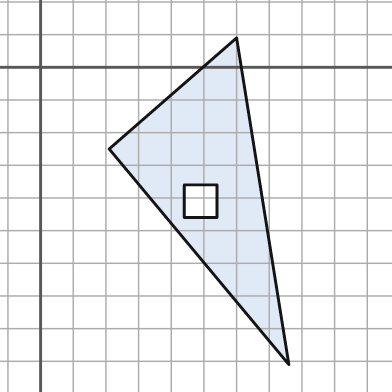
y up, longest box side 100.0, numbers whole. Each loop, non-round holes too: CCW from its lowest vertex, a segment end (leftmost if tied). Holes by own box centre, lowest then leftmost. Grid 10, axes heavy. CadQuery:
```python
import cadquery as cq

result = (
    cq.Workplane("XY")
    .moveTo(76.0, -91.0)
    .lineTo(60.0, 9.0)
    .lineTo(21.0, -25.0)
    .close()
    .moveTo(44.0, -46.0)
    .lineTo(54.0, -46.0)
    .lineTo(54.0, -36.0)
    .lineTo(44.0, -36.0)
    .close()
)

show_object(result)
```